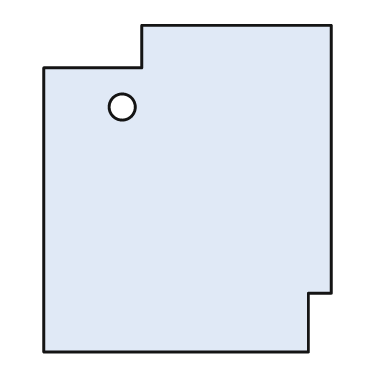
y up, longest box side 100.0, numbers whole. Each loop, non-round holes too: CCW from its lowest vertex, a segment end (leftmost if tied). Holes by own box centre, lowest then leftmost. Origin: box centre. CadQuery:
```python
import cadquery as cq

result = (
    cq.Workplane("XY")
    .moveTo(-44.0, -50.0)
    .lineTo(37.0, -50.0)
    .lineTo(37.0, -32.0)
    .lineTo(44.0, -32.0)
    .lineTo(44.0, 50.0)
    .lineTo(-14.0, 50.0)
    .lineTo(-14.0, 37.0)
    .lineTo(-44.0, 37.0)
    .close()
    .moveTo(-20.0, 25.0)
    .circle(4.0)
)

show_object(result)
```